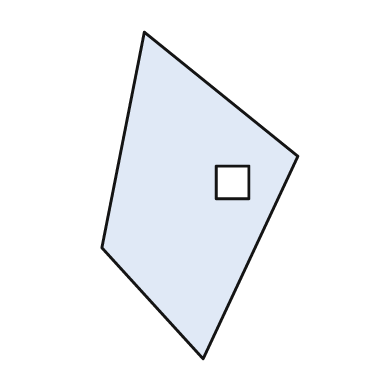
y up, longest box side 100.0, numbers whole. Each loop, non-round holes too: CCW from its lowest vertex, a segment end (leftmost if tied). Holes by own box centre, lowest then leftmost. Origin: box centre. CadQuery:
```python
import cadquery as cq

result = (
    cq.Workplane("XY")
    .moveTo(1.0, -50.0)
    .lineTo(30.0, 12.0)
    .lineTo(-17.0, 50.0)
    .lineTo(-30.0, -16.0)
    .close()
    .moveTo(5.0, -1.0)
    .lineTo(15.0, -1.0)
    .lineTo(15.0, 9.0)
    .lineTo(5.0, 9.0)
    .close()
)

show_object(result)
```